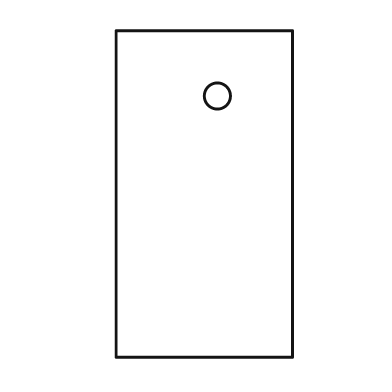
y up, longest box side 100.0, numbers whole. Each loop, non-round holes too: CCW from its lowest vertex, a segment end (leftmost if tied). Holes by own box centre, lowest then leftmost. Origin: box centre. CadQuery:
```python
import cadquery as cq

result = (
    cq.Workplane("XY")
    .moveTo(-27.0, -50.0)
    .lineTo(27.0, -50.0)
    .lineTo(27.0, 50.0)
    .lineTo(-27.0, 50.0)
    .close()
    .moveTo(4.0, 30.0)
    .circle(4.0)
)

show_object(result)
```